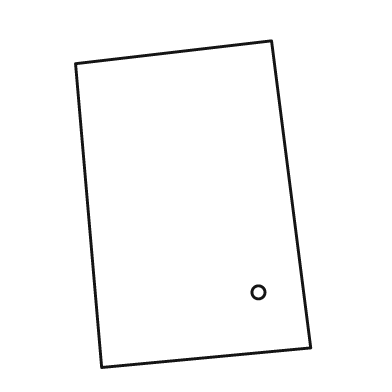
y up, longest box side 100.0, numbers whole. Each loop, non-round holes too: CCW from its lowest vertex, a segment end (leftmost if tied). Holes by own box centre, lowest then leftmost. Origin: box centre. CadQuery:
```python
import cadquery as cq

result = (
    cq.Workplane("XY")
    .moveTo(-28.0, -50.0)
    .lineTo(36.0, -44.0)
    .lineTo(24.0, 50.0)
    .lineTo(-36.0, 43.0)
    .close()
    .moveTo(20.0, -27.0)
    .circle(2.0)
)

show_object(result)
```